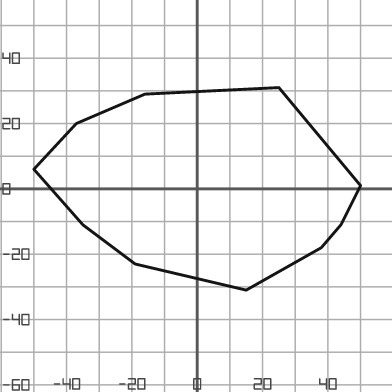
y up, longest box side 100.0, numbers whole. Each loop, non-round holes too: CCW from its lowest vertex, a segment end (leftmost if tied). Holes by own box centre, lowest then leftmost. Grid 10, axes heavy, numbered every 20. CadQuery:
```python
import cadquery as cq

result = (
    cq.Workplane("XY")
    .moveTo(15.0, -31.0)
    .lineTo(38.0, -18.0)
    .lineTo(44.0, -11.0)
    .lineTo(50.0, 1.0)
    .lineTo(25.0, 31.0)
    .lineTo(-16.0, 29.0)
    .lineTo(-37.0, 20.0)
    .lineTo(-50.0, 6.0)
    .lineTo(-35.0, -11.0)
    .lineTo(-19.0, -23.0)
    .close()
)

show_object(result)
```